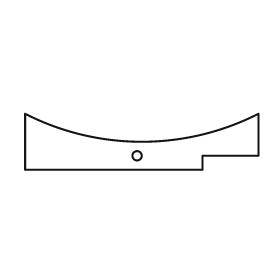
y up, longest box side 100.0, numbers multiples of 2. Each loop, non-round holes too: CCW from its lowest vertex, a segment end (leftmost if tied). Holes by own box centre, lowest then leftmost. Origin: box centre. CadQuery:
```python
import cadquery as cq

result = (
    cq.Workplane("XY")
    .moveTo(-50.0, -12.0)
    .lineTo(26.0, -12.0)
    .lineTo(26.0, -6.0)
    .lineTo(50.0, -6.0)
    .lineTo(50.0, 12.0)
    .threePointArc((0.0, 0.0), (-50.0, 12.0))
    .close()
    .moveTo(-2.0, -6.0)
    .circle(2.0)
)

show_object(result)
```